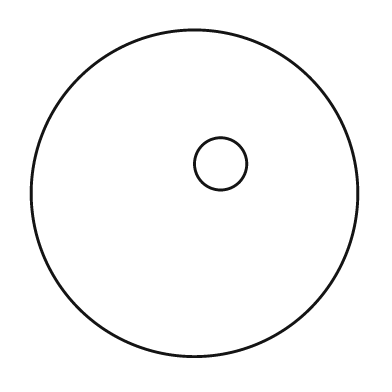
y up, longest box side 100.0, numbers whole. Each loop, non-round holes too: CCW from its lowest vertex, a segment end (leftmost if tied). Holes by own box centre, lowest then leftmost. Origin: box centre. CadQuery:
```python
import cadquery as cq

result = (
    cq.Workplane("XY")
    .moveTo(0.0, 0.0)
    .circle(50.0)
    .moveTo(8.0, 9.0)
    .circle(8.0)
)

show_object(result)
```